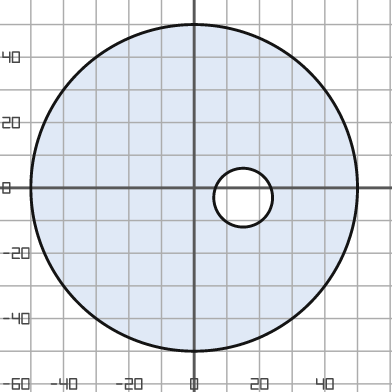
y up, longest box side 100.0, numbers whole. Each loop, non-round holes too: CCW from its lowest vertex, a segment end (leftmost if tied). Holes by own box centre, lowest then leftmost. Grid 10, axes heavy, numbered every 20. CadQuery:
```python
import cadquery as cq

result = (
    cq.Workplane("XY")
    .moveTo(0.0, 0.0)
    .circle(50.0)
    .moveTo(15.0, -3.0)
    .circle(9.0)
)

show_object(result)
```